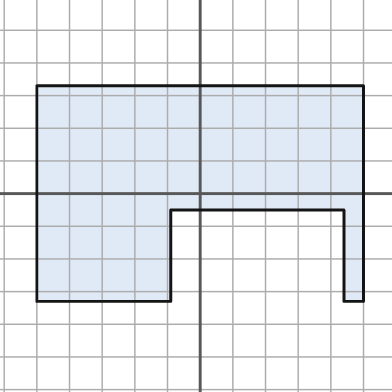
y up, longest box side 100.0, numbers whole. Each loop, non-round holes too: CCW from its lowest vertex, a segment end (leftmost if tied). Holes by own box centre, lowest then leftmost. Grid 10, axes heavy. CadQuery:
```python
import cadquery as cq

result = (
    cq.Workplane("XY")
    .moveTo(-50.0, -33.0)
    .lineTo(-9.0, -33.0)
    .lineTo(-9.0, -5.0)
    .lineTo(44.0, -5.0)
    .lineTo(44.0, -33.0)
    .lineTo(50.0, -33.0)
    .lineTo(50.0, 33.0)
    .lineTo(-50.0, 33.0)
    .close()
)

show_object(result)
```